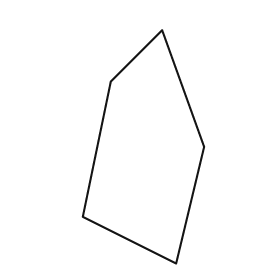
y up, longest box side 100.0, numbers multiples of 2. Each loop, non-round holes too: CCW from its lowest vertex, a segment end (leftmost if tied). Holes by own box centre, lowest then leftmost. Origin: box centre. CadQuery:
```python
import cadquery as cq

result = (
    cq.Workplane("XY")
    .moveTo(14.0, -50.0)
    .lineTo(26.0, 0.0)
    .lineTo(8.0, 50.0)
    .lineTo(-14.0, 28.0)
    .lineTo(-26.0, -30.0)
    .close()
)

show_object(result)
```